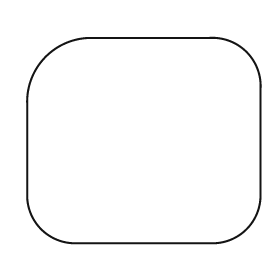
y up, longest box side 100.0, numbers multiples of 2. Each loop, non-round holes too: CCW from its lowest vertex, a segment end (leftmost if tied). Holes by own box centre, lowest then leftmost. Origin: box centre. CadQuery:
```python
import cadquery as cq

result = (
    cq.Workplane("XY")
    .moveTo(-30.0, -44.0)
    .lineTo(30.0, -44.0)
    .threePointArc((44.0, -38.0), (50.0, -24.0))
    .lineTo(50.0, 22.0)
    .threePointArc((44.0, 38.0), (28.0, 44.0))
    .lineTo(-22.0, 44.0)
    .threePointArc((-42.0, 36.0), (-50.0, 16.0))
    .lineTo(-50.0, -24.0)
    .threePointArc((-44.0, -38.0), (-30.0, -44.0))
    .close()
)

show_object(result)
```